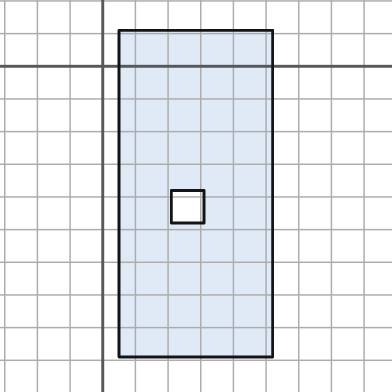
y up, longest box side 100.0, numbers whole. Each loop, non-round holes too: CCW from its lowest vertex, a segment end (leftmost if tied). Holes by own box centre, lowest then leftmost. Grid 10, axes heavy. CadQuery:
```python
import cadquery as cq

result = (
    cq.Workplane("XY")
    .moveTo(5.0, -89.0)
    .lineTo(52.0, -89.0)
    .lineTo(52.0, 11.0)
    .lineTo(5.0, 11.0)
    .close()
    .moveTo(21.0, -48.0)
    .lineTo(31.0, -48.0)
    .lineTo(31.0, -38.0)
    .lineTo(21.0, -38.0)
    .close()
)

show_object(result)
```